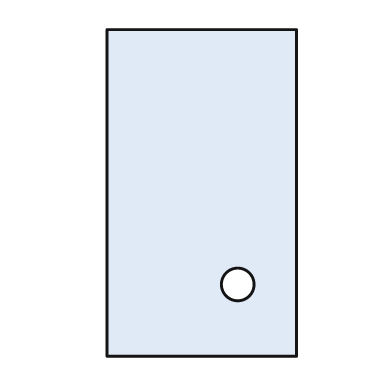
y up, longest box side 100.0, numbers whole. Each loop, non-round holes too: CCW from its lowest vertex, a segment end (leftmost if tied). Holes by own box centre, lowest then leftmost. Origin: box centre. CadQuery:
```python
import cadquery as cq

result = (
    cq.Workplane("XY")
    .moveTo(-29.0, -50.0)
    .lineTo(29.0, -50.0)
    .lineTo(29.0, 50.0)
    .lineTo(-29.0, 50.0)
    .close()
    .moveTo(11.0, -28.0)
    .circle(5.0)
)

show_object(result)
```